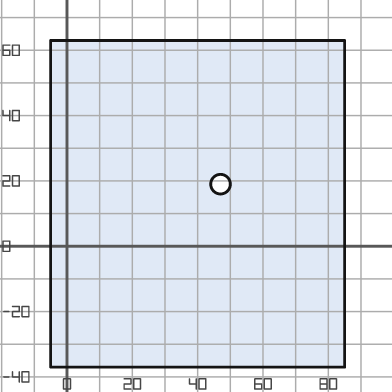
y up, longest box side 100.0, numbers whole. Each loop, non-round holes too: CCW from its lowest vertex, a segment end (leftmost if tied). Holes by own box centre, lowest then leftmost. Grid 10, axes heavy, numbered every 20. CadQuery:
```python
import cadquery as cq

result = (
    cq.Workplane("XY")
    .moveTo(-5.0, -37.0)
    .lineTo(85.0, -37.0)
    .lineTo(85.0, 63.0)
    .lineTo(-5.0, 63.0)
    .close()
    .moveTo(47.0, 19.0)
    .circle(3.0)
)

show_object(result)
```